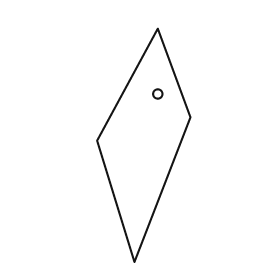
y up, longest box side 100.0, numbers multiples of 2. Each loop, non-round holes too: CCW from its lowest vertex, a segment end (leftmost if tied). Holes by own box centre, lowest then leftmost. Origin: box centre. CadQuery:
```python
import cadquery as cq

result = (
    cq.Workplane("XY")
    .moveTo(-4.0, -50.0)
    .lineTo(20.0, 12.0)
    .lineTo(6.0, 50.0)
    .lineTo(-20.0, 2.0)
    .close()
    .moveTo(6.0, 22.0)
    .circle(2.0)
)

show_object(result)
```